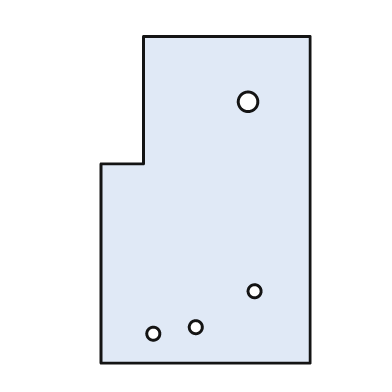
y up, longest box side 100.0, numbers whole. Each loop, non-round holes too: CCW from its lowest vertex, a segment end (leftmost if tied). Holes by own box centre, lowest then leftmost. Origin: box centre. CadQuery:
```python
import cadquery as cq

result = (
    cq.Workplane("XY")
    .moveTo(-32.0, -50.0)
    .lineTo(32.0, -50.0)
    .lineTo(32.0, 50.0)
    .lineTo(-19.0, 50.0)
    .lineTo(-19.0, 11.0)
    .lineTo(-32.0, 11.0)
    .close()
    .moveTo(-16.0, -41.0)
    .circle(2.0)
    .moveTo(-3.0, -39.0)
    .circle(2.0)
    .moveTo(15.0, -28.0)
    .circle(2.0)
    .moveTo(13.0, 30.0)
    .circle(3.0)
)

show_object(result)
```